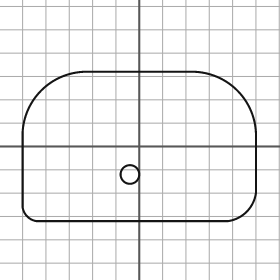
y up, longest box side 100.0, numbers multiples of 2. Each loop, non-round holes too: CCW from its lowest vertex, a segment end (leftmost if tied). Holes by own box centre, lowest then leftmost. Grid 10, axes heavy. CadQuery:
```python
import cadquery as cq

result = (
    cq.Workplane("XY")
    .moveTo(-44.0, -32.0)
    .lineTo(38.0, -32.0)
    .threePointArc((46.0, -28.0), (50.0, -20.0))
    .lineTo(50.0, 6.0)
    .threePointArc((42.0, 24.0), (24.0, 32.0))
    .lineTo(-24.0, 32.0)
    .threePointArc((-42.0, 24.0), (-50.0, 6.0))
    .lineTo(-50.0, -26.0)
    .threePointArc((-48.0, -30.0), (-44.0, -32.0))
    .close()
    .moveTo(-4.0, -12.0)
    .circle(4.0)
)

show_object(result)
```